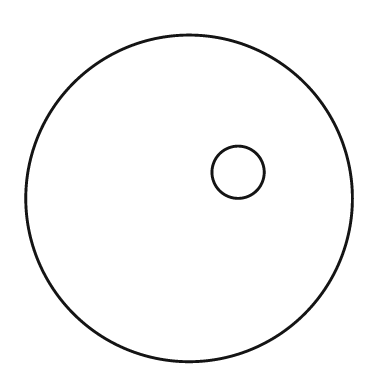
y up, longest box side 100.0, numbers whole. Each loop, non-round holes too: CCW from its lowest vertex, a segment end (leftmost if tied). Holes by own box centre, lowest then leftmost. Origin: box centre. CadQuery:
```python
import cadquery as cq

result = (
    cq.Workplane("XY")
    .moveTo(0.0, 0.0)
    .circle(50.0)
    .moveTo(15.0, 8.0)
    .circle(8.0)
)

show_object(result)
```